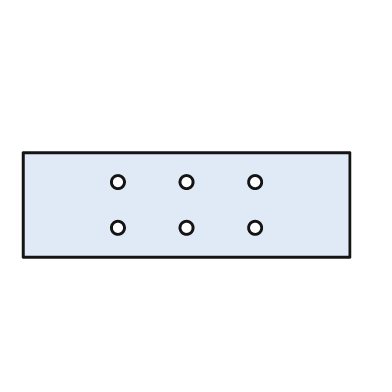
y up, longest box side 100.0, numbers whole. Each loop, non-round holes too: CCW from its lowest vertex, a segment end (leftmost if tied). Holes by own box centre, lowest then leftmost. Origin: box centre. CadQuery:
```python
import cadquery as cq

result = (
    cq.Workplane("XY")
    .moveTo(-50.0, -16.0)
    .lineTo(50.0, -16.0)
    .lineTo(50.0, 16.0)
    .lineTo(-50.0, 16.0)
    .close()
    .moveTo(-21.0, -7.0)
    .circle(2.0)
    .moveTo(0.0, -7.0)
    .circle(2.0)
    .moveTo(21.0, -7.0)
    .circle(2.0)
    .moveTo(-21.0, 7.0)
    .circle(2.0)
    .moveTo(0.0, 7.0)
    .circle(2.0)
    .moveTo(21.0, 7.0)
    .circle(2.0)
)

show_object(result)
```